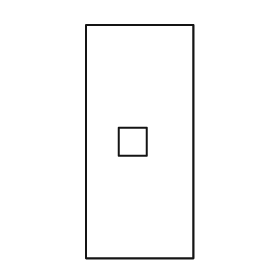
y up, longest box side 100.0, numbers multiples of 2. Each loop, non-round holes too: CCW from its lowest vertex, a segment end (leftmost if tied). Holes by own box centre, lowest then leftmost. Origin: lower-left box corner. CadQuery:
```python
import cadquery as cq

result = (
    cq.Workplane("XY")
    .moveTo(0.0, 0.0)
    .lineTo(46.0, 0.0)
    .lineTo(46.0, 100.0)
    .lineTo(0.0, 100.0)
    .close()
    .moveTo(14.0, 44.0)
    .lineTo(26.0, 44.0)
    .lineTo(26.0, 56.0)
    .lineTo(14.0, 56.0)
    .close()
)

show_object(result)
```